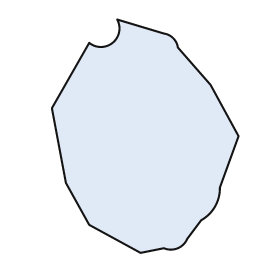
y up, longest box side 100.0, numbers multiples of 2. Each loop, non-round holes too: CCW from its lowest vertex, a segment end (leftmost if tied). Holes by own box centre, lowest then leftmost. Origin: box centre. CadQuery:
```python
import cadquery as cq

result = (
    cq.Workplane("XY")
    .moveTo(-2.0, -50.0)
    .lineTo(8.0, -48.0)
    .threePointArc((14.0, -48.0), (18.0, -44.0))
    .lineTo(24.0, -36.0)
    .threePointArc((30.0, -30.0), (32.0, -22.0))
    .lineTo(40.0, 0.0)
    .lineTo(28.0, 22.0)
    .lineTo(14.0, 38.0)
    .threePointArc((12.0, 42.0), (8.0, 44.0))
    .lineTo(-12.0, 50.0)
    .threePointArc((-14.0, 40.0), (-24.0, 40.0))
    .lineTo(-40.0, 12.0)
    .lineTo(-34.0, -20.0)
    .lineTo(-24.0, -38.0)
    .close()
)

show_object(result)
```